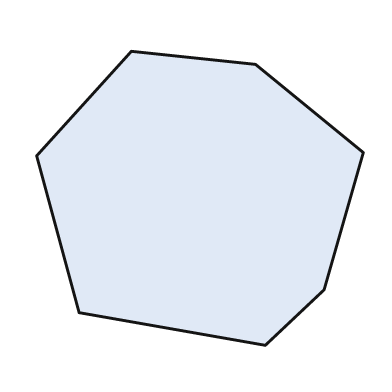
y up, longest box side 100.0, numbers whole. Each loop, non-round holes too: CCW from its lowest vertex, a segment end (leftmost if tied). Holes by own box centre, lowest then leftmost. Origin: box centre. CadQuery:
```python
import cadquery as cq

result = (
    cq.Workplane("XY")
    .moveTo(20.0, -45.0)
    .lineTo(38.0, -28.0)
    .lineTo(50.0, 14.0)
    .lineTo(17.0, 41.0)
    .lineTo(-21.0, 45.0)
    .lineTo(-50.0, 13.0)
    .lineTo(-37.0, -35.0)
    .close()
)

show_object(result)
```